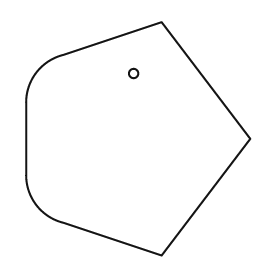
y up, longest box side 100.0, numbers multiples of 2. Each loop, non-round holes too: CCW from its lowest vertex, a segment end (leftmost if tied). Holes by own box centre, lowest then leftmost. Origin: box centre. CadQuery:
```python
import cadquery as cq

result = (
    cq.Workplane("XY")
    .moveTo(10.0, -50.0)
    .lineTo(48.0, 0.0)
    .lineTo(10.0, 50.0)
    .lineTo(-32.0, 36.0)
    .threePointArc((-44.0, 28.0), (-48.0, 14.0))
    .lineTo(-48.0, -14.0)
    .threePointArc((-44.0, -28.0), (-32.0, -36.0))
    .close()
    .moveTo(-2.0, 28.0)
    .circle(2.0)
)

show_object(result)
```